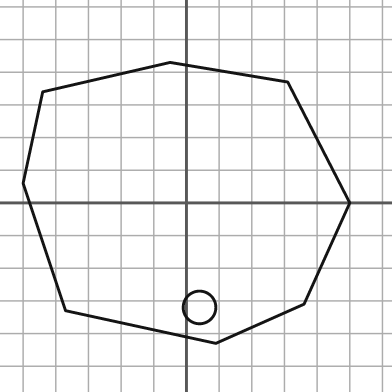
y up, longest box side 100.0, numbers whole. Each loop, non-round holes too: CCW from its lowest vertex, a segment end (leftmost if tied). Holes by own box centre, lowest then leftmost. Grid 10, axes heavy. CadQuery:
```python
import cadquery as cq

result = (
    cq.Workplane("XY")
    .moveTo(9.0, -43.0)
    .lineTo(36.0, -31.0)
    .lineTo(50.0, 0.0)
    .lineTo(31.0, 37.0)
    .lineTo(-5.0, 43.0)
    .lineTo(-44.0, 34.0)
    .lineTo(-50.0, 6.0)
    .lineTo(-37.0, -33.0)
    .close()
    .moveTo(4.0, -32.0)
    .circle(5.0)
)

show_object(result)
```